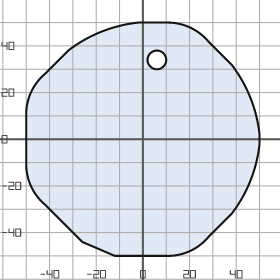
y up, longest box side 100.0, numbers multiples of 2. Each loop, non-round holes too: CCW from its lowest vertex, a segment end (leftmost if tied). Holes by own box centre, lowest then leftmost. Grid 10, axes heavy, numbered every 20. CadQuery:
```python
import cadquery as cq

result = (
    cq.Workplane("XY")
    .moveTo(-12.0, -50.0)
    .lineTo(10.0, -50.0)
    .threePointArc((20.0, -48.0), (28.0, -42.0))
    .lineTo(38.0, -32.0)
    .threePointArc((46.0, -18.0), (50.0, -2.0))
    .lineTo(50.0, 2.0)
    .threePointArc((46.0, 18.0), (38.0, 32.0))
    .lineTo(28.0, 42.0)
    .threePointArc((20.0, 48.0), (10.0, 50.0))
    .lineTo(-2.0, 50.0)
    .threePointArc((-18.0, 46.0), (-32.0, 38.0))
    .lineTo(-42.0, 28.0)
    .threePointArc((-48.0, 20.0), (-50.0, 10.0))
    .lineTo(-50.0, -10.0)
    .threePointArc((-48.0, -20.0), (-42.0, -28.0))
    .lineTo(-26.0, -44.0)
    .close()
    .moveTo(6.0, 34.0)
    .circle(4.0)
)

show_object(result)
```